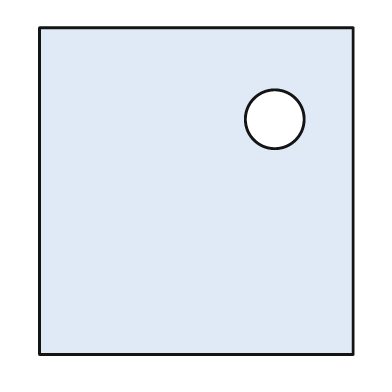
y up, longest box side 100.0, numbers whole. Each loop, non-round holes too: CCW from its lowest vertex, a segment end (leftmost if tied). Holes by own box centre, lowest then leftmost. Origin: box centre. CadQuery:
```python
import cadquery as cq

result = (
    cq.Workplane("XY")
    .moveTo(-48.0, -50.0)
    .lineTo(48.0, -50.0)
    .lineTo(48.0, 50.0)
    .lineTo(-48.0, 50.0)
    .close()
    .moveTo(24.0, 22.0)
    .circle(9.0)
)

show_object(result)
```